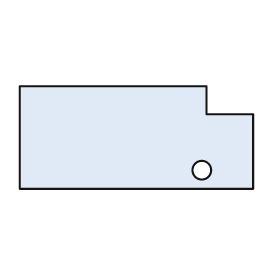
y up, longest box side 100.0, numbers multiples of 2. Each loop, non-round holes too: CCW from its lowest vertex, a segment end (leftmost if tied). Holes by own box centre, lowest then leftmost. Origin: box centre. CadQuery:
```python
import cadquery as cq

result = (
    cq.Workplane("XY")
    .moveTo(-50.0, -22.0)
    .lineTo(50.0, -22.0)
    .lineTo(50.0, 10.0)
    .lineTo(30.0, 10.0)
    .lineTo(30.0, 22.0)
    .lineTo(-50.0, 22.0)
    .close()
    .moveTo(28.0, -14.0)
    .circle(4.0)
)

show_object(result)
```